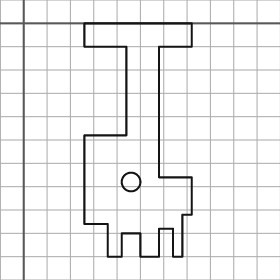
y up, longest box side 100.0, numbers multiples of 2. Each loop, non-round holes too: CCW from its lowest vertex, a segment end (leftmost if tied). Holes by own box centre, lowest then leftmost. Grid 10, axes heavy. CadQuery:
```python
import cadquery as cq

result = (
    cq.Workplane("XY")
    .moveTo(36.0, -100.0)
    .lineTo(42.0, -100.0)
    .lineTo(42.0, -90.0)
    .lineTo(50.0, -90.0)
    .lineTo(50.0, -100.0)
    .lineTo(58.0, -100.0)
    .lineTo(58.0, -88.0)
    .lineTo(64.0, -88.0)
    .lineTo(64.0, -100.0)
    .lineTo(68.0, -100.0)
    .lineTo(68.0, -82.0)
    .lineTo(72.0, -82.0)
    .lineTo(72.0, -66.0)
    .lineTo(58.0, -66.0)
    .lineTo(58.0, -10.0)
    .lineTo(72.0, -10.0)
    .lineTo(72.0, 0.0)
    .lineTo(26.0, 0.0)
    .lineTo(26.0, -10.0)
    .lineTo(44.0, -10.0)
    .lineTo(44.0, -48.0)
    .lineTo(26.0, -48.0)
    .lineTo(26.0, -86.0)
    .lineTo(36.0, -86.0)
    .close()
    .moveTo(46.0, -68.0)
    .circle(4.0)
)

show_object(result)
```